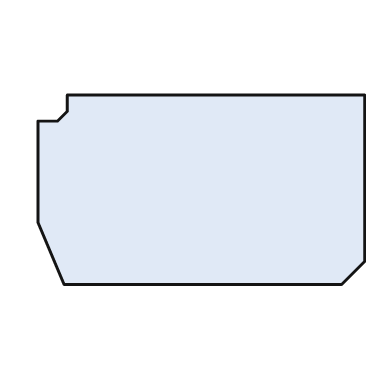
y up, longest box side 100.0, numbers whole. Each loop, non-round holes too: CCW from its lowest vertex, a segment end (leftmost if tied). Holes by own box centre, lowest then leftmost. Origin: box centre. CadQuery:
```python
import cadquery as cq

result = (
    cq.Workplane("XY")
    .moveTo(-42.0, -29.0)
    .lineTo(43.0, -29.0)
    .lineTo(50.0, -22.0)
    .lineTo(50.0, 29.0)
    .lineTo(-41.0, 29.0)
    .lineTo(-41.0, 24.0)
    .lineTo(-44.0, 21.0)
    .lineTo(-50.0, 21.0)
    .lineTo(-50.0, -10.0)
    .close()
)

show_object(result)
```